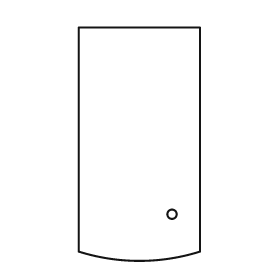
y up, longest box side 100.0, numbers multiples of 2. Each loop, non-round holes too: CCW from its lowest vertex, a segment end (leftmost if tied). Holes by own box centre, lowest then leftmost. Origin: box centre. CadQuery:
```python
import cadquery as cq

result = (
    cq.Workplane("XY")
    .moveTo(-26.0, -46.0)
    .threePointArc((0.0, -50.0), (26.0, -46.0))
    .lineTo(26.0, 50.0)
    .lineTo(-26.0, 50.0)
    .close()
    .moveTo(14.0, -30.0)
    .circle(2.0)
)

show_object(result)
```